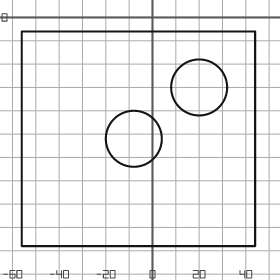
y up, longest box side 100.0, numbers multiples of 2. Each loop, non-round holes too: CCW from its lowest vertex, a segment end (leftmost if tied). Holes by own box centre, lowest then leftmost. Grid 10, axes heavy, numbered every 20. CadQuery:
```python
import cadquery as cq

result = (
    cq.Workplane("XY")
    .moveTo(-56.0, -98.0)
    .lineTo(44.0, -98.0)
    .lineTo(44.0, -6.0)
    .lineTo(-56.0, -6.0)
    .close()
    .moveTo(-8.0, -52.0)
    .circle(12.0)
    .moveTo(20.0, -30.0)
    .circle(12.0)
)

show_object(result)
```